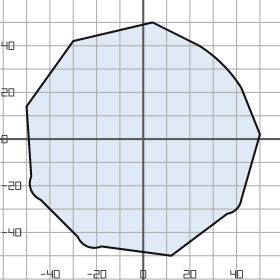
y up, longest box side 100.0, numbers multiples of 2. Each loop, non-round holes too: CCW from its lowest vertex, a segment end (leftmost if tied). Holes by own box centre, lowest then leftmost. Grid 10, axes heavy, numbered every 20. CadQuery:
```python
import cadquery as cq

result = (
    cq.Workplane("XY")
    .moveTo(12.0, -50.0)
    .lineTo(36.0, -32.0)
    .threePointArc((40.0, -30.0), (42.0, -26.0))
    .lineTo(50.0, 2.0)
    .lineTo(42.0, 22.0)
    .threePointArc((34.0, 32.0), (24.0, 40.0))
    .lineTo(4.0, 50.0)
    .lineTo(-30.0, 42.0)
    .lineTo(-50.0, 14.0)
    .lineTo(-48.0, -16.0)
    .threePointArc((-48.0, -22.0), (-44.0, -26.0))
    .lineTo(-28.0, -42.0)
    .threePointArc((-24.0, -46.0), (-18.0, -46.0))
    .close()
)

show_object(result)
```